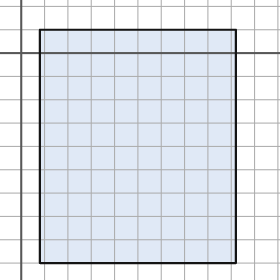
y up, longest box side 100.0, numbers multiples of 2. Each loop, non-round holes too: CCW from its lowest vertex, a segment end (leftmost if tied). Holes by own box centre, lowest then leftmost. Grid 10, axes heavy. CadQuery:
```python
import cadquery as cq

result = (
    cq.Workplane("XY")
    .moveTo(8.0, -90.0)
    .lineTo(92.0, -90.0)
    .lineTo(92.0, 10.0)
    .lineTo(8.0, 10.0)
    .close()
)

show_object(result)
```